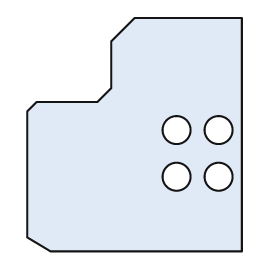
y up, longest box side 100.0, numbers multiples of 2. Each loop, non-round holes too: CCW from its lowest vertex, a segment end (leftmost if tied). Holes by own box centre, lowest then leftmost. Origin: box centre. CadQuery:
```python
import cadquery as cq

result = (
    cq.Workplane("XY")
    .moveTo(-36.0, -50.0)
    .lineTo(46.0, -50.0)
    .lineTo(46.0, 50.0)
    .lineTo(0.0, 50.0)
    .lineTo(-10.0, 40.0)
    .lineTo(-10.0, 20.0)
    .lineTo(-16.0, 14.0)
    .lineTo(-42.0, 14.0)
    .lineTo(-46.0, 10.0)
    .lineTo(-46.0, -44.0)
    .close()
    .moveTo(18.0, -18.0)
    .circle(6.0)
    .moveTo(36.0, -18.0)
    .circle(6.0)
    .moveTo(18.0, 2.0)
    .circle(6.0)
    .moveTo(36.0, 2.0)
    .circle(6.0)
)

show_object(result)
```